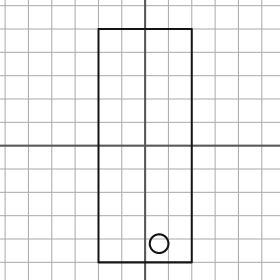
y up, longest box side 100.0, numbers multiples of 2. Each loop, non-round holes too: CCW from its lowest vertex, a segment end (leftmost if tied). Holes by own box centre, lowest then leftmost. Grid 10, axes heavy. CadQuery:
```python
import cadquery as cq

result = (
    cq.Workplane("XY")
    .moveTo(-20.0, -50.0)
    .lineTo(20.0, -50.0)
    .lineTo(20.0, 50.0)
    .lineTo(-20.0, 50.0)
    .close()
    .moveTo(6.0, -42.0)
    .circle(4.0)
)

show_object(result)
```